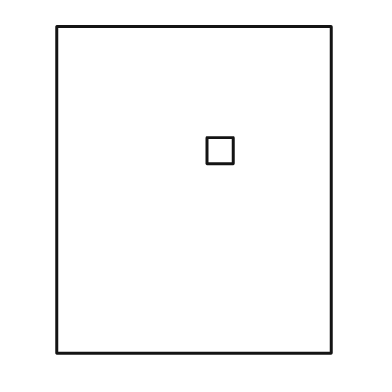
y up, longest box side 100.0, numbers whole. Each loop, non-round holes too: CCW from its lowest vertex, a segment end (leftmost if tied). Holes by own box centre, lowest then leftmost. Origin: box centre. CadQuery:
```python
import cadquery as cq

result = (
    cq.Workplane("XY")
    .moveTo(-42.0, -50.0)
    .lineTo(42.0, -50.0)
    .lineTo(42.0, 50.0)
    .lineTo(-42.0, 50.0)
    .close()
    .moveTo(4.0, 8.0)
    .lineTo(12.0, 8.0)
    .lineTo(12.0, 16.0)
    .lineTo(4.0, 16.0)
    .close()
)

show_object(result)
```